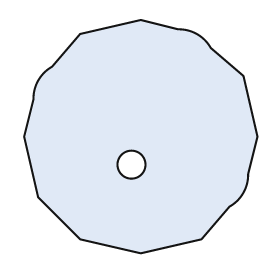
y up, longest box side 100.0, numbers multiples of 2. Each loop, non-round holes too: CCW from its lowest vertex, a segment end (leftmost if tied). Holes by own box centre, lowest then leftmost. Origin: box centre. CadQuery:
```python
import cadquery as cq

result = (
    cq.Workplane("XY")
    .moveTo(0.0, -50.0)
    .lineTo(26.0, -44.0)
    .lineTo(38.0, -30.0)
    .threePointArc((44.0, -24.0), (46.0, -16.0))
    .lineTo(50.0, 0.0)
    .lineTo(44.0, 26.0)
    .lineTo(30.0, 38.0)
    .threePointArc((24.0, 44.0), (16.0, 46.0))
    .lineTo(0.0, 50.0)
    .lineTo(-26.0, 44.0)
    .lineTo(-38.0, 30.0)
    .threePointArc((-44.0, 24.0), (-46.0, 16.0))
    .lineTo(-50.0, 0.0)
    .lineTo(-44.0, -26.0)
    .lineTo(-26.0, -44.0)
    .close()
    .moveTo(-4.0, -12.0)
    .circle(6.0)
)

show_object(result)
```